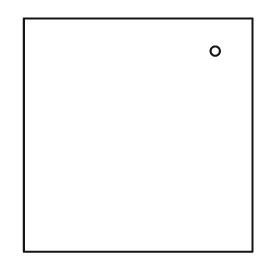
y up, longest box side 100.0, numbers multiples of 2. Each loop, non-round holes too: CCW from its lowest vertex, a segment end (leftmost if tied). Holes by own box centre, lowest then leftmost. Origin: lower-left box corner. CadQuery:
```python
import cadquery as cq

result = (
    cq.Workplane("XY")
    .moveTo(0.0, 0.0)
    .lineTo(98.0, 0.0)
    .lineTo(98.0, 100.0)
    .lineTo(0.0, 100.0)
    .close()
    .moveTo(82.0, 86.0)
    .circle(2.0)
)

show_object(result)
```